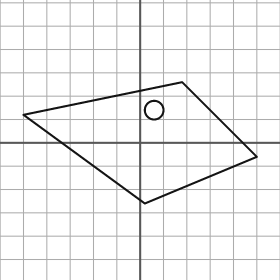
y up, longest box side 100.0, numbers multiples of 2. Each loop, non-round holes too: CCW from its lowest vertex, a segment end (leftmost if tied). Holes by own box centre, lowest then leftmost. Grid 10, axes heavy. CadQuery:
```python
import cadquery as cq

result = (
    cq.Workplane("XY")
    .moveTo(2.0, -26.0)
    .lineTo(50.0, -6.0)
    .lineTo(18.0, 26.0)
    .lineTo(-50.0, 12.0)
    .close()
    .moveTo(6.0, 14.0)
    .circle(4.0)
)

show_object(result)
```